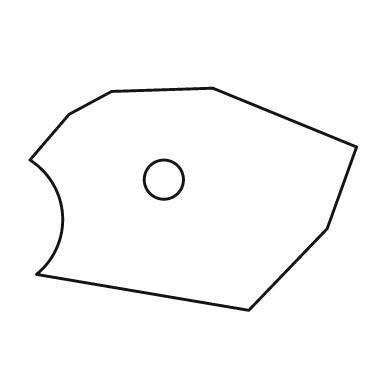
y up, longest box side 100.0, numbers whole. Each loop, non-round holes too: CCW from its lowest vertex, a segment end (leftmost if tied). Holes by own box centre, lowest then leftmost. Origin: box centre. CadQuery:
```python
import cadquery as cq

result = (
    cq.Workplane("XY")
    .moveTo(17.0, -34.0)
    .lineTo(41.0, -9.0)
    .lineTo(50.0, 16.0)
    .lineTo(6.0, 34.0)
    .lineTo(-25.0, 33.0)
    .lineTo(-38.0, 26.0)
    .lineTo(-50.0, 12.0)
    .threePointArc((-40.0, -5.0), (-48.0, -23.0))
    .close()
    .moveTo(-9.0, 6.0)
    .circle(6.0)
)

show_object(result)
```